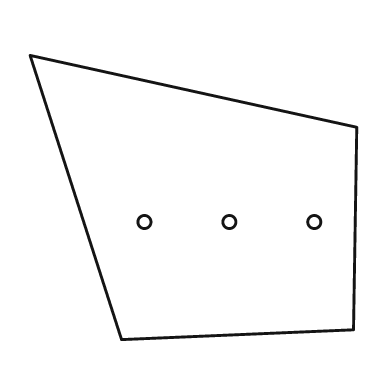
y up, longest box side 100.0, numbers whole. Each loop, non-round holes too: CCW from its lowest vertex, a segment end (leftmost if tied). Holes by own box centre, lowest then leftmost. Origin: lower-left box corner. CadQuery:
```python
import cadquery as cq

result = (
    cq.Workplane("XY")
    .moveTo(28.0, 0.0)
    .lineTo(99.0, 3.0)
    .lineTo(100.0, 65.0)
    .lineTo(0.0, 87.0)
    .close()
    .moveTo(35.0, 36.0)
    .circle(2.0)
    .moveTo(61.0, 36.0)
    .circle(2.0)
    .moveTo(87.0, 36.0)
    .circle(2.0)
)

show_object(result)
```